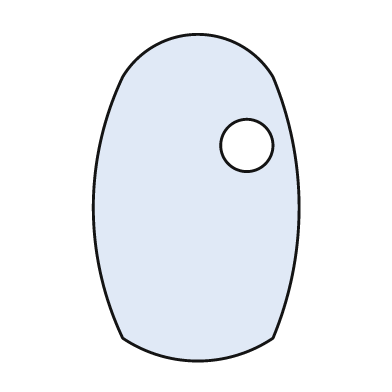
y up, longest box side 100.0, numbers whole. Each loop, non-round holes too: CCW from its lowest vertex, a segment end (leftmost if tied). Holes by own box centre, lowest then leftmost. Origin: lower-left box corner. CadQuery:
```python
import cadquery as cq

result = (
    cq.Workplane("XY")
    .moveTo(9.0, 7.0)
    .threePointArc((32.0, 0.0), (55.0, 7.0))
    .threePointArc((63.0, 47.0), (55.0, 87.0))
    .threePointArc((32.0, 100.0), (9.0, 87.0))
    .threePointArc((0.0, 47.0), (9.0, 7.0))
    .close()
    .moveTo(47.0, 66.0)
    .circle(8.0)
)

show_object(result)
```